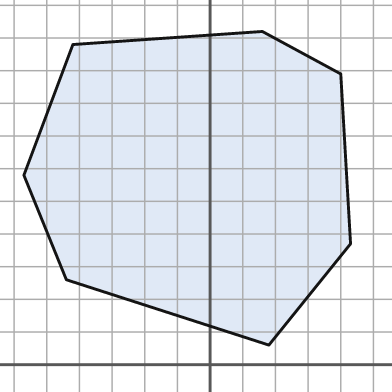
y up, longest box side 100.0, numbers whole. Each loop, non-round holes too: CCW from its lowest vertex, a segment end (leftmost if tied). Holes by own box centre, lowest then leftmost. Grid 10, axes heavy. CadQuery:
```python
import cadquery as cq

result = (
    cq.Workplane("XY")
    .moveTo(18.0, 6.0)
    .lineTo(43.0, 37.0)
    .lineTo(40.0, 89.0)
    .lineTo(16.0, 102.0)
    .lineTo(-42.0, 98.0)
    .lineTo(-57.0, 58.0)
    .lineTo(-44.0, 26.0)
    .close()
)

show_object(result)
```